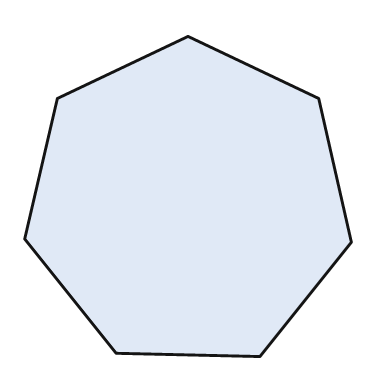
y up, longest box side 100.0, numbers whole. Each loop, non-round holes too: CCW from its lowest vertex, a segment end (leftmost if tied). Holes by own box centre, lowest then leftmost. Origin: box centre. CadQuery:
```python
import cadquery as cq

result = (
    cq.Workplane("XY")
    .moveTo(22.0, -49.0)
    .lineTo(50.0, -14.0)
    .lineTo(40.0, 30.0)
    .lineTo(0.0, 49.0)
    .lineTo(-40.0, 30.0)
    .lineTo(-50.0, -13.0)
    .lineTo(-22.0, -48.0)
    .close()
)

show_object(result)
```